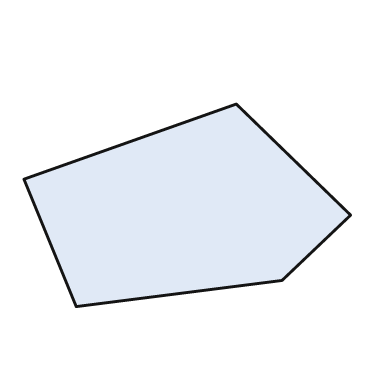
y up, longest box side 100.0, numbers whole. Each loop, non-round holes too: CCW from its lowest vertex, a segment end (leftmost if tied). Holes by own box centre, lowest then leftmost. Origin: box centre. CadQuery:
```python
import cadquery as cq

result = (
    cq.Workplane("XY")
    .moveTo(-34.0, -31.0)
    .lineTo(29.0, -23.0)
    .lineTo(50.0, -3.0)
    .lineTo(15.0, 31.0)
    .lineTo(-50.0, 8.0)
    .close()
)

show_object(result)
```